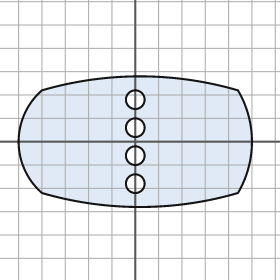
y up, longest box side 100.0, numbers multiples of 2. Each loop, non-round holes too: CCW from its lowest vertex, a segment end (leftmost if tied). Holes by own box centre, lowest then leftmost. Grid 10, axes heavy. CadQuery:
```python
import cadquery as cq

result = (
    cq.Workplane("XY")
    .moveTo(-40.0, -22.0)
    .threePointArc((2.0, -28.0), (44.0, -22.0))
    .threePointArc((50.0, 0.0), (44.0, 22.0))
    .threePointArc((2.0, 28.0), (-40.0, 22.0))
    .threePointArc((-50.0, 0.0), (-40.0, -22.0))
    .close()
    .moveTo(0.0, -18.0)
    .circle(4.0)
    .moveTo(0.0, -6.0)
    .circle(4.0)
    .moveTo(0.0, 6.0)
    .circle(4.0)
    .moveTo(0.0, 18.0)
    .circle(4.0)
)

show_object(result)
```